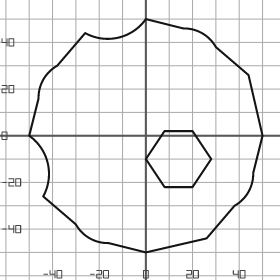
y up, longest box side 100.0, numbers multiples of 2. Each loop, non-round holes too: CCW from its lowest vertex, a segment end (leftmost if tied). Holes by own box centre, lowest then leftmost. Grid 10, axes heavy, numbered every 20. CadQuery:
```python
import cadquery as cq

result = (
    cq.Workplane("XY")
    .moveTo(0.0, -50.0)
    .lineTo(26.0, -44.0)
    .lineTo(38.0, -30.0)
    .threePointArc((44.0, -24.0), (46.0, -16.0))
    .lineTo(50.0, 0.0)
    .lineTo(44.0, 26.0)
    .lineTo(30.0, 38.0)
    .threePointArc((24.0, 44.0), (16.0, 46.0))
    .lineTo(0.0, 50.0)
    .threePointArc((-12.0, 42.0), (-26.0, 44.0))
    .lineTo(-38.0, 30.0)
    .threePointArc((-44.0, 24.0), (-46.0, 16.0))
    .lineTo(-50.0, 0.0)
    .threePointArc((-42.0, -12.0), (-44.0, -26.0))
    .lineTo(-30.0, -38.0)
    .threePointArc((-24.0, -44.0), (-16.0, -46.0))
    .close()
    .moveTo(8.0, -22.0)
    .lineTo(20.0, -22.0)
    .lineTo(28.0, -10.0)
    .lineTo(20.0, 2.0)
    .lineTo(8.0, 2.0)
    .lineTo(0.0, -10.0)
    .close()
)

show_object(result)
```